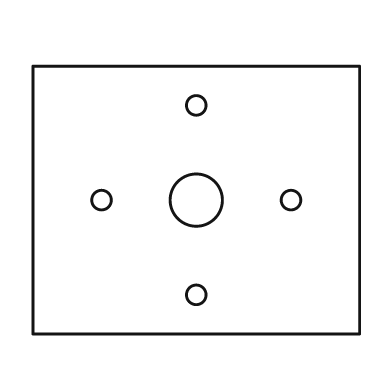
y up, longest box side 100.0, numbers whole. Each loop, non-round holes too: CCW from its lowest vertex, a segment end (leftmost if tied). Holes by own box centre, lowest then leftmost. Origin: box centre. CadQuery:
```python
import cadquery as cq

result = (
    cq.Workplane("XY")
    .moveTo(-50.0, -41.0)
    .lineTo(50.0, -41.0)
    .lineTo(50.0, 41.0)
    .lineTo(-50.0, 41.0)
    .close()
    .moveTo(0.0, -29.0)
    .circle(3.0)
    .moveTo(-29.0, 0.0)
    .circle(3.0)
    .moveTo(0.0, 0.0)
    .circle(8.0)
    .moveTo(29.0, 0.0)
    .circle(3.0)
    .moveTo(0.0, 29.0)
    .circle(3.0)
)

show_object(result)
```